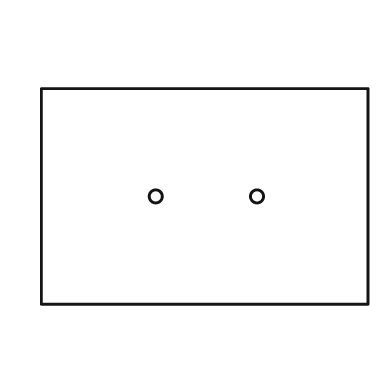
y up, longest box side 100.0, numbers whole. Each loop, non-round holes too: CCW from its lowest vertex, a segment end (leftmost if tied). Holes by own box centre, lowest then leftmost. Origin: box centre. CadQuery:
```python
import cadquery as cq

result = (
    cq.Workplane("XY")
    .moveTo(-50.0, -33.0)
    .lineTo(50.0, -33.0)
    .lineTo(50.0, 33.0)
    .lineTo(-50.0, 33.0)
    .close()
    .moveTo(-15.0, 0.0)
    .circle(2.0)
    .moveTo(16.0, 0.0)
    .circle(2.0)
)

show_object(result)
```